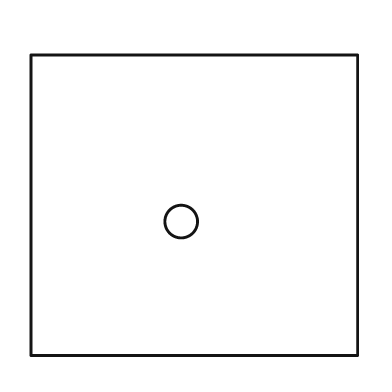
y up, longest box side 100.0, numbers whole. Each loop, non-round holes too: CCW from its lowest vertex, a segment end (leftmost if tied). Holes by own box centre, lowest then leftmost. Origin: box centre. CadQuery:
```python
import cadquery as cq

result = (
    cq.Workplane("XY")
    .moveTo(-50.0, -46.0)
    .lineTo(50.0, -46.0)
    .lineTo(50.0, 46.0)
    .lineTo(-50.0, 46.0)
    .close()
    .moveTo(-4.0, -5.0)
    .circle(5.0)
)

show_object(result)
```